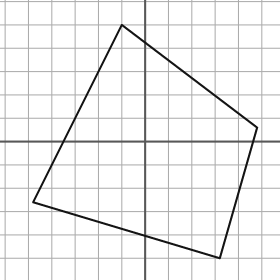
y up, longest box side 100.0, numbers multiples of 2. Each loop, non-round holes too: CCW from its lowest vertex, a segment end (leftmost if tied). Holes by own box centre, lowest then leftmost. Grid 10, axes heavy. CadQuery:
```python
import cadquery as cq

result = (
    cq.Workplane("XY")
    .moveTo(32.0, -50.0)
    .lineTo(48.0, 6.0)
    .lineTo(-10.0, 50.0)
    .lineTo(-48.0, -26.0)
    .close()
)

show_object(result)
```